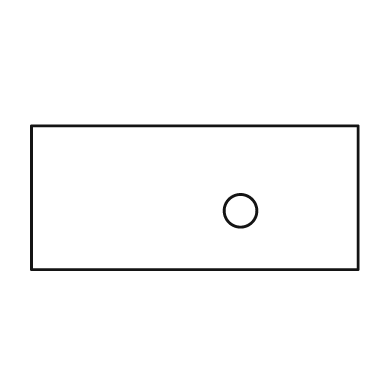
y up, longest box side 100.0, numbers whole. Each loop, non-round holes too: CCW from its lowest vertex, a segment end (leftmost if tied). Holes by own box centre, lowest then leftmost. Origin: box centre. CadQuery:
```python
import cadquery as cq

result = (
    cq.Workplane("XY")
    .moveTo(-50.0, -22.0)
    .lineTo(50.0, -22.0)
    .lineTo(50.0, 22.0)
    .lineTo(-50.0, 22.0)
    .close()
    .moveTo(14.0, -4.0)
    .circle(5.0)
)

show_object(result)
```